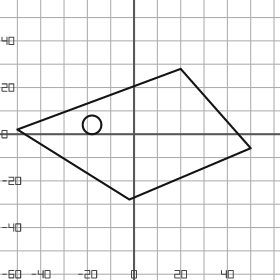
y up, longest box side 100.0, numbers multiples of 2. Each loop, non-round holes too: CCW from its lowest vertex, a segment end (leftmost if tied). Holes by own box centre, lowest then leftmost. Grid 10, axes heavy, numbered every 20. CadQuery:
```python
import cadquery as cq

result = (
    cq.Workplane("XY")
    .moveTo(-2.0, -28.0)
    .lineTo(50.0, -6.0)
    .lineTo(20.0, 28.0)
    .lineTo(-50.0, 2.0)
    .close()
    .moveTo(-18.0, 4.0)
    .circle(4.0)
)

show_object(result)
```